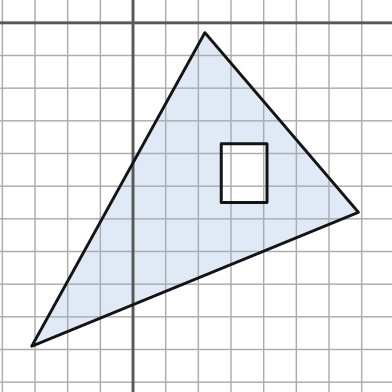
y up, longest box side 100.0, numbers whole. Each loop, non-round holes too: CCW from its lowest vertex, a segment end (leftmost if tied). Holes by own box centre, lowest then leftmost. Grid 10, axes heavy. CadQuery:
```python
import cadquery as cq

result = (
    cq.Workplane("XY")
    .moveTo(-31.0, -99.0)
    .lineTo(69.0, -58.0)
    .lineTo(22.0, -3.0)
    .close()
    .moveTo(27.0, -55.0)
    .lineTo(41.0, -55.0)
    .lineTo(41.0, -37.0)
    .lineTo(27.0, -37.0)
    .close()
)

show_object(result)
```